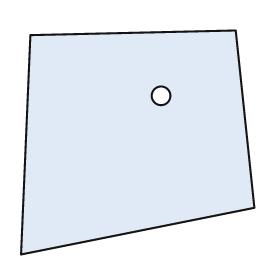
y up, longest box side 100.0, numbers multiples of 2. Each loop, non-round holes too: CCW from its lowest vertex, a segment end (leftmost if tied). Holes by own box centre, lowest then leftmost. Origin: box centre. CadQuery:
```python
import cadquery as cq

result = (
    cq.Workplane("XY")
    .moveTo(-50.0, -48.0)
    .lineTo(50.0, -28.0)
    .lineTo(42.0, 48.0)
    .lineTo(-46.0, 46.0)
    .close()
    .moveTo(10.0, 20.0)
    .circle(4.0)
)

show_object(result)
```